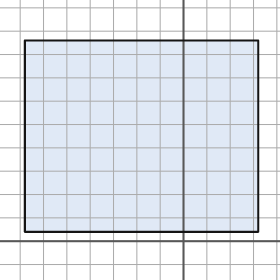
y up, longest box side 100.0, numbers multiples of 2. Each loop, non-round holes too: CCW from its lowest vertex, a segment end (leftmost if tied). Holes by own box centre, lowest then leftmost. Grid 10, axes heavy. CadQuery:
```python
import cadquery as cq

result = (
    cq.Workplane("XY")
    .moveTo(-68.0, 4.0)
    .lineTo(32.0, 4.0)
    .lineTo(32.0, 86.0)
    .lineTo(-68.0, 86.0)
    .close()
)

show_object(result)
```